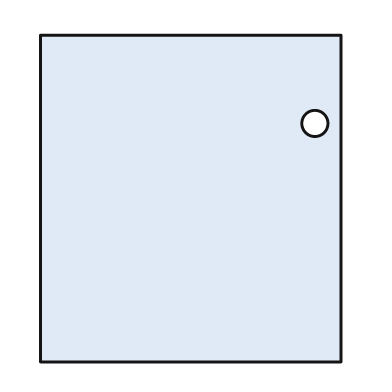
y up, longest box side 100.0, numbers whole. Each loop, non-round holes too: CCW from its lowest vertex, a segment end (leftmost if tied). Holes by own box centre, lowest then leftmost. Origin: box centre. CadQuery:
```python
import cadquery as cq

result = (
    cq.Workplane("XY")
    .moveTo(-46.0, -50.0)
    .lineTo(46.0, -50.0)
    .lineTo(46.0, 50.0)
    .lineTo(-46.0, 50.0)
    .close()
    .moveTo(38.0, 23.0)
    .circle(4.0)
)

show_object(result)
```